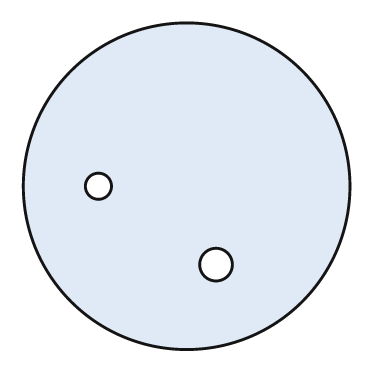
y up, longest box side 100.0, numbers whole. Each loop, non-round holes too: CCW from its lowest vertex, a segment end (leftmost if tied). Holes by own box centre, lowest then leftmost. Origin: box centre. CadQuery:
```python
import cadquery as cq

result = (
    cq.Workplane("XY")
    .moveTo(0.0, 0.0)
    .circle(50.0)
    .moveTo(9.0, -24.0)
    .circle(5.0)
    .moveTo(-27.0, 0.0)
    .circle(4.0)
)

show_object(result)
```